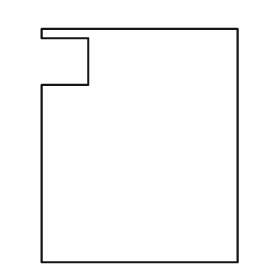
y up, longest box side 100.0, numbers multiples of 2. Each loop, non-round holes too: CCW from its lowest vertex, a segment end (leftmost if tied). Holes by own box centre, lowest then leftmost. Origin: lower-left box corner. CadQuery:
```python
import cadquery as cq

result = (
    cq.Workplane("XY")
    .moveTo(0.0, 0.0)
    .lineTo(84.0, 0.0)
    .lineTo(84.0, 100.0)
    .lineTo(0.0, 100.0)
    .lineTo(0.0, 96.0)
    .lineTo(20.0, 96.0)
    .lineTo(20.0, 76.0)
    .lineTo(0.0, 76.0)
    .close()
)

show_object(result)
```